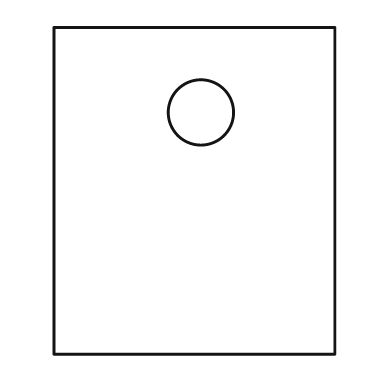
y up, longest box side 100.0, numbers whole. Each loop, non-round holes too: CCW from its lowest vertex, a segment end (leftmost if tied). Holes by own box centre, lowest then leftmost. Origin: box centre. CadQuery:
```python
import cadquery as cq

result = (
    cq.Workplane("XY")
    .moveTo(-43.0, -50.0)
    .lineTo(43.0, -50.0)
    .lineTo(43.0, 50.0)
    .lineTo(-43.0, 50.0)
    .close()
    .moveTo(2.0, 24.0)
    .circle(10.0)
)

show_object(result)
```